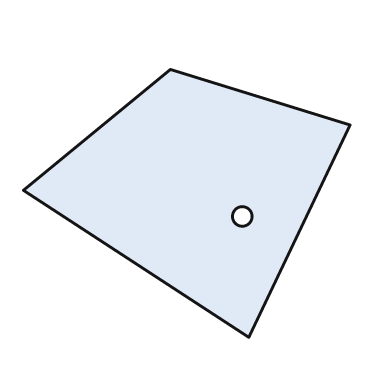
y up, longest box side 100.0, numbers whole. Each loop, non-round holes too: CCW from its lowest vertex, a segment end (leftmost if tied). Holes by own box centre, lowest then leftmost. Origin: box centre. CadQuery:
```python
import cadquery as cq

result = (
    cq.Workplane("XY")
    .moveTo(19.0, -41.0)
    .lineTo(50.0, 24.0)
    .lineTo(-5.0, 41.0)
    .lineTo(-50.0, 4.0)
    .close()
    .moveTo(17.0, -4.0)
    .circle(3.0)
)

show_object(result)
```